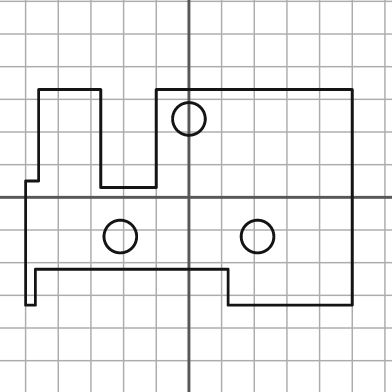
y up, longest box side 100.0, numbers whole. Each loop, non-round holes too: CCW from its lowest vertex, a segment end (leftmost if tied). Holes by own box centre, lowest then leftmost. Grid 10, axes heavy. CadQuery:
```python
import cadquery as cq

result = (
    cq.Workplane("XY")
    .moveTo(-50.0, -33.0)
    .lineTo(-47.0, -33.0)
    .lineTo(-47.0, -22.0)
    .lineTo(12.0, -22.0)
    .lineTo(12.0, -33.0)
    .lineTo(50.0, -33.0)
    .lineTo(50.0, 33.0)
    .lineTo(-10.0, 33.0)
    .lineTo(-10.0, 3.0)
    .lineTo(-27.0, 3.0)
    .lineTo(-27.0, 33.0)
    .lineTo(-46.0, 33.0)
    .lineTo(-46.0, 5.0)
    .lineTo(-50.0, 5.0)
    .close()
    .moveTo(-21.0, -12.0)
    .circle(5.0)
    .moveTo(21.0, -12.0)
    .circle(5.0)
    .moveTo(0.0, 24.0)
    .circle(5.0)
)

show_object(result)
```